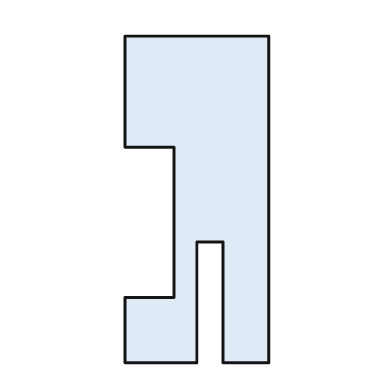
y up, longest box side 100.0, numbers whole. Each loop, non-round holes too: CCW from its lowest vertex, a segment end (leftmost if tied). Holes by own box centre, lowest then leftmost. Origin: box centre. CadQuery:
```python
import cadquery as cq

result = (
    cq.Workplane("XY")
    .moveTo(-22.0, -50.0)
    .lineTo(0.0, -50.0)
    .lineTo(0.0, -13.0)
    .lineTo(8.0, -13.0)
    .lineTo(8.0, -50.0)
    .lineTo(22.0, -50.0)
    .lineTo(22.0, 50.0)
    .lineTo(-22.0, 50.0)
    .lineTo(-22.0, 16.0)
    .lineTo(-7.0, 16.0)
    .lineTo(-7.0, -30.0)
    .lineTo(-22.0, -30.0)
    .close()
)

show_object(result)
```